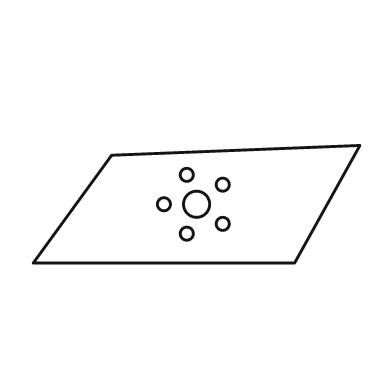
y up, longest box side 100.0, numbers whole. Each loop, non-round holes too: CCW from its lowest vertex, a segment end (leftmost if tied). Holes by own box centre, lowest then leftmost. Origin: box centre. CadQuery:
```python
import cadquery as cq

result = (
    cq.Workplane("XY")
    .moveTo(-50.0, -18.0)
    .lineTo(30.0, -18.0)
    .lineTo(50.0, 18.0)
    .lineTo(-26.0, 15.0)
    .close()
    .moveTo(-3.0, -9.0)
    .circle(2.0)
    .moveTo(8.0, -6.0)
    .circle(2.0)
    .moveTo(-10.0, 0.0)
    .circle(2.0)
    .moveTo(0.0, 0.0)
    .circle(4.0)
    .moveTo(8.0, 6.0)
    .circle(2.0)
    .moveTo(-3.0, 9.0)
    .circle(2.0)
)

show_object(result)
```